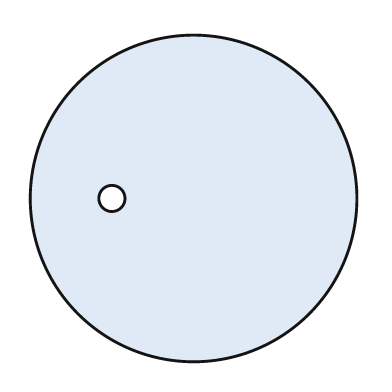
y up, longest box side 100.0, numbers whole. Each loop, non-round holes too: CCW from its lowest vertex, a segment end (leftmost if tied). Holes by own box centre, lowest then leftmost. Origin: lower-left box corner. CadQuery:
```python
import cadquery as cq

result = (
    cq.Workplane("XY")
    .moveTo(50.0, 50.0)
    .circle(50.0)
    .moveTo(25.0, 50.0)
    .circle(4.0)
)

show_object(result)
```